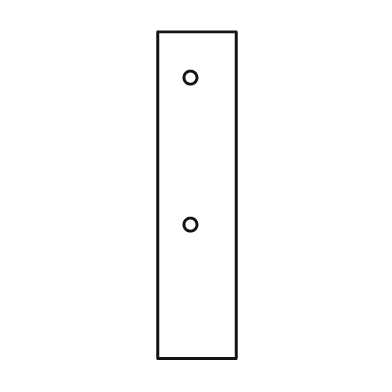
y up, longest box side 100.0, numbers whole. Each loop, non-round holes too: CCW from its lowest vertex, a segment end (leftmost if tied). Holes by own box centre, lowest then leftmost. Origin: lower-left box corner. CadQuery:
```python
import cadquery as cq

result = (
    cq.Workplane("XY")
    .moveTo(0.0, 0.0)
    .lineTo(24.0, 0.0)
    .lineTo(24.0, 100.0)
    .lineTo(0.0, 100.0)
    .close()
    .moveTo(10.0, 41.0)
    .circle(2.0)
    .moveTo(10.0, 86.0)
    .circle(2.0)
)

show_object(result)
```